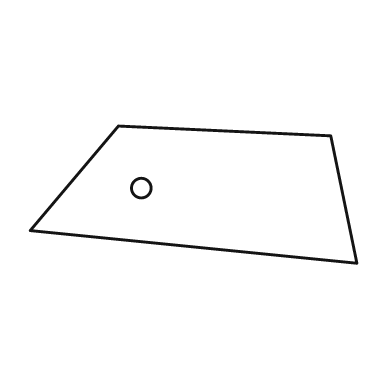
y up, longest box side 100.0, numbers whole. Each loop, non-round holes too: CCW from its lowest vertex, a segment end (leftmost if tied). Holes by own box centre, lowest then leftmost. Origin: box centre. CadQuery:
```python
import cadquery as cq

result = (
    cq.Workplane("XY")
    .moveTo(50.0, -21.0)
    .lineTo(42.0, 18.0)
    .lineTo(-23.0, 21.0)
    .lineTo(-50.0, -11.0)
    .close()
    .moveTo(-16.0, 2.0)
    .circle(3.0)
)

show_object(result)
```